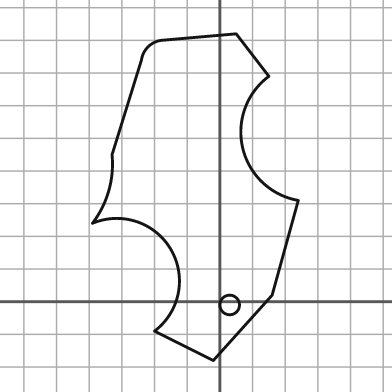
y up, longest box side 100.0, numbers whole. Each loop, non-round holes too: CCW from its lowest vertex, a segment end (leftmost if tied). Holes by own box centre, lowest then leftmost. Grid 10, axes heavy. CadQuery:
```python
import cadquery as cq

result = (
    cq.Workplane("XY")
    .moveTo(-2.0, -18.0)
    .lineTo(16.0, 2.0)
    .lineTo(24.0, 31.0)
    .threePointArc((7.0, 47.0), (15.0, 69.0))
    .lineTo(5.0, 82.0)
    .lineTo(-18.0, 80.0)
    .threePointArc((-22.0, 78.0), (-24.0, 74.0))
    .lineTo(-33.0, 45.0)
    .threePointArc((-34.0, 34.0), (-39.0, 24.0))
    .threePointArc((-15.0, 16.0), (-20.0, -9.0))
    .close()
    .moveTo(3.0, -1.0)
    .circle(3.0)
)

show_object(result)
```